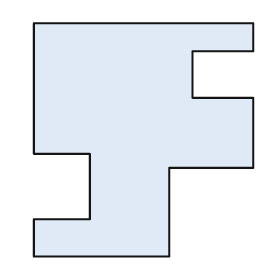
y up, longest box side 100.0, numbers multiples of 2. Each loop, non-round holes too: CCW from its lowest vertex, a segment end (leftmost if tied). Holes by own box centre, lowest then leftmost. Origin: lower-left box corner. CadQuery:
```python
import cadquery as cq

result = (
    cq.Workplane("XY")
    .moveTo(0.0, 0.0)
    .lineTo(58.0, 0.0)
    .lineTo(58.0, 38.0)
    .lineTo(94.0, 38.0)
    .lineTo(94.0, 68.0)
    .lineTo(68.0, 68.0)
    .lineTo(68.0, 88.0)
    .lineTo(94.0, 88.0)
    .lineTo(94.0, 100.0)
    .lineTo(0.0, 100.0)
    .lineTo(0.0, 44.0)
    .lineTo(24.0, 44.0)
    .lineTo(24.0, 16.0)
    .lineTo(0.0, 16.0)
    .close()
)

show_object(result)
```